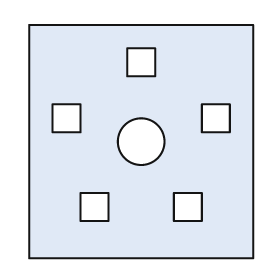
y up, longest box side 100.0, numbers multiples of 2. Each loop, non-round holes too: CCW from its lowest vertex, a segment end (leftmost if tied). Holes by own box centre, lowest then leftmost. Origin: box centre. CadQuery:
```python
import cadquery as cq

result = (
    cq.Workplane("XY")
    .moveTo(-48.0, -50.0)
    .lineTo(48.0, -50.0)
    .lineTo(48.0, 50.0)
    .lineTo(-48.0, 50.0)
    .close()
    .moveTo(-26.0, -34.0)
    .lineTo(-14.0, -34.0)
    .lineTo(-14.0, -22.0)
    .lineTo(-26.0, -22.0)
    .close()
    .moveTo(14.0, -34.0)
    .lineTo(26.0, -34.0)
    .lineTo(26.0, -22.0)
    .lineTo(14.0, -22.0)
    .close()
    .moveTo(0.0, 0.0)
    .circle(10.0)
    .moveTo(-38.0, 4.0)
    .lineTo(-26.0, 4.0)
    .lineTo(-26.0, 16.0)
    .lineTo(-38.0, 16.0)
    .close()
    .moveTo(26.0, 4.0)
    .lineTo(38.0, 4.0)
    .lineTo(38.0, 16.0)
    .lineTo(26.0, 16.0)
    .close()
    .moveTo(-6.0, 28.0)
    .lineTo(6.0, 28.0)
    .lineTo(6.0, 40.0)
    .lineTo(-6.0, 40.0)
    .close()
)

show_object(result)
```